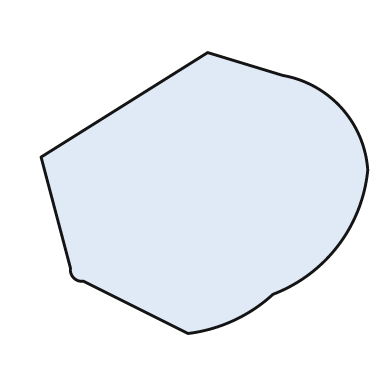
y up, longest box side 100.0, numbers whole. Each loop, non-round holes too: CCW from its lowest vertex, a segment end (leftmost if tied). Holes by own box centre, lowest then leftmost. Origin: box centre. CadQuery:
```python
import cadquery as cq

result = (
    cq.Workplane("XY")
    .moveTo(-5.0, -43.0)
    .threePointArc((9.0, -39.0), (21.0, -31.0))
    .threePointArc((41.0, -16.0), (50.0, 7.0))
    .threePointArc((42.0, 26.0), (24.0, 36.0))
    .lineTo(1.0, 43.0)
    .lineTo(-50.0, 11.0)
    .lineTo(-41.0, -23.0)
    .threePointArc((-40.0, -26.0), (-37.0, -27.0))
    .close()
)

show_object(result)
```